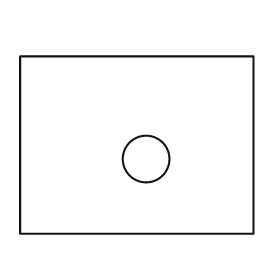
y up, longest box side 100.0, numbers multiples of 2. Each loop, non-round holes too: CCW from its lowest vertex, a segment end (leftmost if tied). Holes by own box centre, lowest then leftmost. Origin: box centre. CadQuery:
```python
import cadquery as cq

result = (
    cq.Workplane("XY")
    .moveTo(-50.0, -38.0)
    .lineTo(50.0, -38.0)
    .lineTo(50.0, 38.0)
    .lineTo(-50.0, 38.0)
    .close()
    .moveTo(4.0, -6.0)
    .circle(10.0)
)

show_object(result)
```